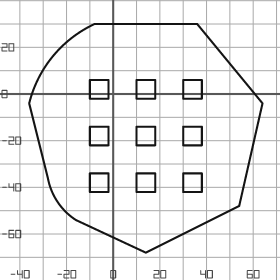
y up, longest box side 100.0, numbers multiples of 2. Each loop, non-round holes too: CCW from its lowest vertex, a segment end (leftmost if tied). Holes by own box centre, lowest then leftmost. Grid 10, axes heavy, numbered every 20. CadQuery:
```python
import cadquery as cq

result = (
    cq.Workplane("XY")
    .moveTo(14.0, -68.0)
    .lineTo(54.0, -48.0)
    .lineTo(64.0, -4.0)
    .lineTo(36.0, 30.0)
    .lineTo(-8.0, 30.0)
    .threePointArc((-26.0, 16.0), (-36.0, -4.0))
    .lineTo(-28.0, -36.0)
    .threePointArc((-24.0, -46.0), (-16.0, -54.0))
    .close()
    .moveTo(-10.0, -42.0)
    .lineTo(-2.0, -42.0)
    .lineTo(-2.0, -34.0)
    .lineTo(-10.0, -34.0)
    .close()
    .moveTo(10.0, -42.0)
    .lineTo(18.0, -42.0)
    .lineTo(18.0, -34.0)
    .lineTo(10.0, -34.0)
    .close()
    .moveTo(30.0, -42.0)
    .lineTo(38.0, -42.0)
    .lineTo(38.0, -34.0)
    .lineTo(30.0, -34.0)
    .close()
    .moveTo(-10.0, -22.0)
    .lineTo(-2.0, -22.0)
    .lineTo(-2.0, -14.0)
    .lineTo(-10.0, -14.0)
    .close()
    .moveTo(10.0, -22.0)
    .lineTo(18.0, -22.0)
    .lineTo(18.0, -14.0)
    .lineTo(10.0, -14.0)
    .close()
    .moveTo(30.0, -22.0)
    .lineTo(38.0, -22.0)
    .lineTo(38.0, -14.0)
    .lineTo(30.0, -14.0)
    .close()
    .moveTo(-10.0, -2.0)
    .lineTo(-2.0, -2.0)
    .lineTo(-2.0, 6.0)
    .lineTo(-10.0, 6.0)
    .close()
    .moveTo(10.0, -2.0)
    .lineTo(18.0, -2.0)
    .lineTo(18.0, 6.0)
    .lineTo(10.0, 6.0)
    .close()
    .moveTo(30.0, -2.0)
    .lineTo(38.0, -2.0)
    .lineTo(38.0, 6.0)
    .lineTo(30.0, 6.0)
    .close()
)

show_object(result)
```